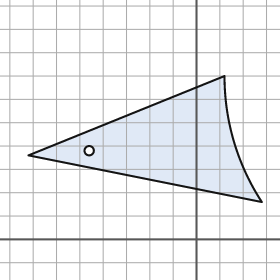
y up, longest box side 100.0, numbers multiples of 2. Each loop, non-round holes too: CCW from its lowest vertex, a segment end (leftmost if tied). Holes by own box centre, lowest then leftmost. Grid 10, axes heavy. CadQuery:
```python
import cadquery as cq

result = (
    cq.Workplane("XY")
    .moveTo(28.0, 16.0)
    .threePointArc((16.0, 42.0), (12.0, 70.0))
    .lineTo(-72.0, 36.0)
    .close()
    .moveTo(-46.0, 38.0)
    .circle(2.0)
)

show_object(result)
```